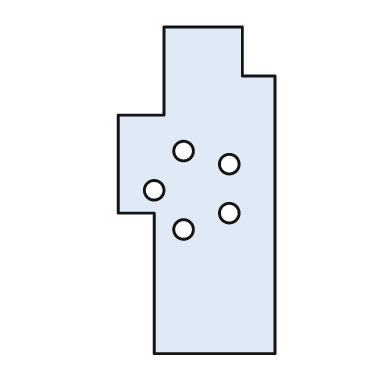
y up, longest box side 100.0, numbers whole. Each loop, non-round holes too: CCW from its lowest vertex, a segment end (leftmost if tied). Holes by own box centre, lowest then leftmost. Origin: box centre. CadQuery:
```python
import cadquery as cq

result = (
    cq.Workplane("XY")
    .moveTo(-13.0, -50.0)
    .lineTo(24.0, -50.0)
    .lineTo(24.0, 35.0)
    .lineTo(14.0, 35.0)
    .lineTo(14.0, 50.0)
    .lineTo(-10.0, 50.0)
    .lineTo(-10.0, 23.0)
    .lineTo(-24.0, 23.0)
    .lineTo(-24.0, -7.0)
    .lineTo(-13.0, -7.0)
    .close()
    .moveTo(-4.0, -12.0)
    .circle(3.0)
    .moveTo(10.0, -7.0)
    .circle(3.0)
    .moveTo(-13.0, 0.0)
    .circle(3.0)
    .moveTo(10.0, 8.0)
    .circle(3.0)
    .moveTo(-4.0, 12.0)
    .circle(3.0)
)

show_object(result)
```